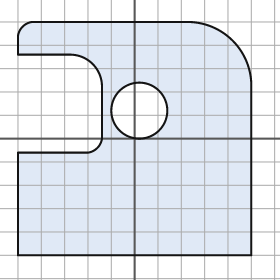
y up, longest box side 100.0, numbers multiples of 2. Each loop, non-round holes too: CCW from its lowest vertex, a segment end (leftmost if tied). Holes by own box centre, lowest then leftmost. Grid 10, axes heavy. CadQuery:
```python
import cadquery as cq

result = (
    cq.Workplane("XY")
    .moveTo(-50.0, -50.0)
    .lineTo(50.0, -50.0)
    .lineTo(50.0, 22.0)
    .threePointArc((42.0, 42.0), (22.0, 50.0))
    .lineTo(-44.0, 50.0)
    .threePointArc((-48.0, 48.0), (-50.0, 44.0))
    .lineTo(-50.0, 36.0)
    .lineTo(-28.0, 36.0)
    .threePointArc((-18.0, 32.0), (-14.0, 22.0))
    .lineTo(-14.0, 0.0)
    .threePointArc((-16.0, -4.0), (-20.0, -6.0))
    .lineTo(-50.0, -6.0)
    .close()
    .moveTo(2.0, 12.0)
    .circle(12.0)
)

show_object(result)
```